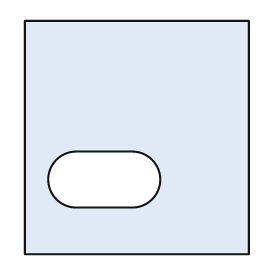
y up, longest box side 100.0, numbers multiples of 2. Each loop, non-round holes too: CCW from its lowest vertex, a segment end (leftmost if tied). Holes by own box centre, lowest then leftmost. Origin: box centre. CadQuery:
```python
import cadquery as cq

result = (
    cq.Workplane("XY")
    .moveTo(-48.0, -50.0)
    .lineTo(48.0, -50.0)
    .lineTo(48.0, 50.0)
    .lineTo(-48.0, 50.0)
    .close()
    .moveTo(-26.0, -30.0)
    .lineTo(-2.0, -30.0)
    .threePointArc((10.0, -18.0), (-2.0, -6.0))
    .lineTo(-26.0, -6.0)
    .threePointArc((-38.0, -18.0), (-26.0, -30.0))
    .close()
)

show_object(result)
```